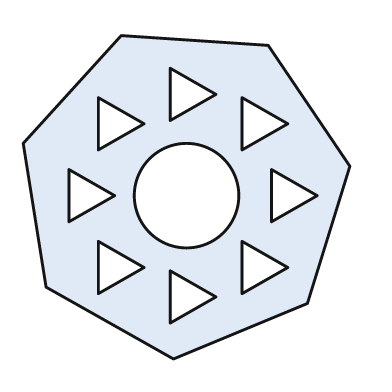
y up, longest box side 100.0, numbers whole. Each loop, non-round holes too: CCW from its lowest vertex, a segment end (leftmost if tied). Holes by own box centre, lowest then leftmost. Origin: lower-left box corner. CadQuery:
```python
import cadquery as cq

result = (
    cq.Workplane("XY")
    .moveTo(46.0, 0.0)
    .lineTo(87.0, 17.0)
    .lineTo(100.0, 59.0)
    .lineTo(75.0, 96.0)
    .lineTo(30.0, 99.0)
    .lineTo(0.0, 66.0)
    .lineTo(7.0, 22.0)
    .close()
    .moveTo(45.0, 11.0)
    .lineTo(59.0, 19.0)
    .lineTo(45.0, 27.0)
    .close()
    .moveTo(23.0, 20.0)
    .lineTo(37.0, 28.0)
    .lineTo(23.0, 36.0)
    .close()
    .moveTo(67.0, 20.0)
    .lineTo(81.0, 28.0)
    .lineTo(67.0, 36.0)
    .close()
    .moveTo(14.0, 42.0)
    .lineTo(28.0, 50.0)
    .lineTo(14.0, 58.0)
    .close()
    .moveTo(50.0, 50.0)
    .circle(16.0)
    .moveTo(76.0, 42.0)
    .lineTo(90.0, 50.0)
    .lineTo(76.0, 58.0)
    .close()
    .moveTo(23.0, 64.0)
    .lineTo(37.0, 72.0)
    .lineTo(23.0, 80.0)
    .close()
    .moveTo(67.0, 64.0)
    .lineTo(81.0, 72.0)
    .lineTo(67.0, 80.0)
    .close()
    .moveTo(45.0, 73.0)
    .lineTo(59.0, 81.0)
    .lineTo(45.0, 89.0)
    .close()
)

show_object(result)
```